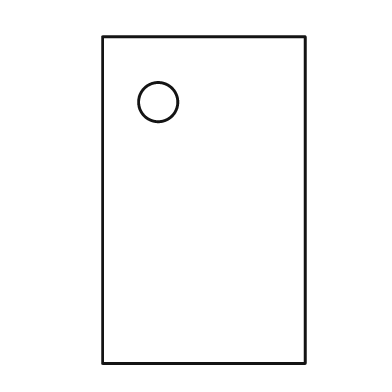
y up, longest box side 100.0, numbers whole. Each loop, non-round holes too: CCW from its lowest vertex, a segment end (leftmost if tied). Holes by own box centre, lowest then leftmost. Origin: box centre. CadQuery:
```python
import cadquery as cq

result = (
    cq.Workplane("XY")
    .moveTo(-31.0, -50.0)
    .lineTo(31.0, -50.0)
    .lineTo(31.0, 50.0)
    .lineTo(-31.0, 50.0)
    .close()
    .moveTo(-14.0, 30.0)
    .circle(6.0)
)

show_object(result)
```